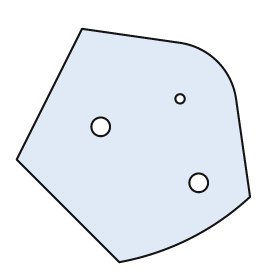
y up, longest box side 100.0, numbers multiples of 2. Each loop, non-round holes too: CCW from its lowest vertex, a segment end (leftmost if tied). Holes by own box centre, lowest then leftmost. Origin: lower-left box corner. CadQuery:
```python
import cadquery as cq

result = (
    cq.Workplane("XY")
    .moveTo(44.0, 0.0)
    .threePointArc((74.0, 10.0), (100.0, 28.0))
    .lineTo(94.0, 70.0)
    .threePointArc((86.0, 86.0), (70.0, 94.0))
    .lineTo(28.0, 100.0)
    .lineTo(0.0, 44.0)
    .close()
    .moveTo(78.0, 34.0)
    .circle(4.0)
    .moveTo(36.0, 58.0)
    .circle(4.0)
    .moveTo(70.0, 70.0)
    .circle(2.0)
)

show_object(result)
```